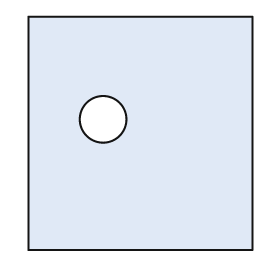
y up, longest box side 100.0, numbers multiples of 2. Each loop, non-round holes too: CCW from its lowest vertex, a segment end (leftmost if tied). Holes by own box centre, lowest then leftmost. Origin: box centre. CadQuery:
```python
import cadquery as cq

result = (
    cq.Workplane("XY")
    .moveTo(-48.0, -50.0)
    .lineTo(48.0, -50.0)
    .lineTo(48.0, 50.0)
    .lineTo(-48.0, 50.0)
    .close()
    .moveTo(-16.0, 6.0)
    .circle(10.0)
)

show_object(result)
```